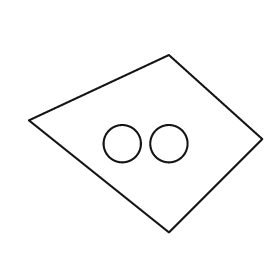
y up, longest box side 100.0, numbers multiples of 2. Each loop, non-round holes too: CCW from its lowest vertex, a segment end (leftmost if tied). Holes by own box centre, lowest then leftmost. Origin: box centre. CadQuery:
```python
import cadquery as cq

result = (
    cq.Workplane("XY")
    .moveTo(10.0, -38.0)
    .lineTo(50.0, 2.0)
    .lineTo(10.0, 38.0)
    .lineTo(-50.0, 10.0)
    .close()
    .moveTo(-10.0, 0.0)
    .circle(8.0)
    .moveTo(10.0, 0.0)
    .circle(8.0)
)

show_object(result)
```